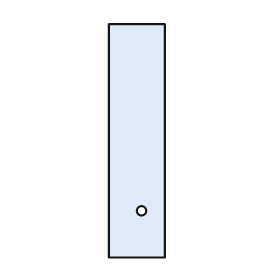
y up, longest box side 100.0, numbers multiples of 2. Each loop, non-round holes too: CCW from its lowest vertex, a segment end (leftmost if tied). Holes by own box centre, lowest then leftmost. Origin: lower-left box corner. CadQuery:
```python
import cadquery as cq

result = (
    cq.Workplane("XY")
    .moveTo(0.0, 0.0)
    .lineTo(24.0, 0.0)
    .lineTo(24.0, 100.0)
    .lineTo(0.0, 100.0)
    .close()
    .moveTo(14.0, 20.0)
    .circle(2.0)
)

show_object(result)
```